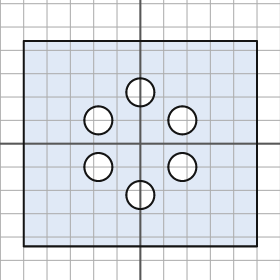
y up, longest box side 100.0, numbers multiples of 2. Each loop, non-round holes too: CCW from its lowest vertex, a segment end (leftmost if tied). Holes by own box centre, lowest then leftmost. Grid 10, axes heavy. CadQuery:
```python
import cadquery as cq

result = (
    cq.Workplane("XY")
    .moveTo(-50.0, -44.0)
    .lineTo(50.0, -44.0)
    .lineTo(50.0, 44.0)
    .lineTo(-50.0, 44.0)
    .close()
    .moveTo(0.0, -22.0)
    .circle(6.0)
    .moveTo(-18.0, -10.0)
    .circle(6.0)
    .moveTo(18.0, -10.0)
    .circle(6.0)
    .moveTo(-18.0, 10.0)
    .circle(6.0)
    .moveTo(18.0, 10.0)
    .circle(6.0)
    .moveTo(0.0, 22.0)
    .circle(6.0)
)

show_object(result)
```